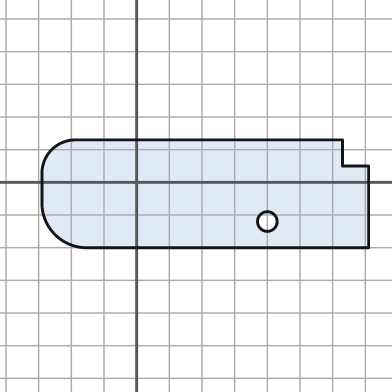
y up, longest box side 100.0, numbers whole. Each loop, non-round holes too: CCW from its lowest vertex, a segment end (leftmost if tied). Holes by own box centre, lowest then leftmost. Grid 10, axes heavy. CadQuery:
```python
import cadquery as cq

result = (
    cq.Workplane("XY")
    .moveTo(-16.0, -20.0)
    .lineTo(71.0, -20.0)
    .lineTo(71.0, 5.0)
    .lineTo(63.0, 5.0)
    .lineTo(63.0, 13.0)
    .lineTo(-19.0, 13.0)
    .threePointArc((-26.0, 10.0), (-29.0, 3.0))
    .lineTo(-29.0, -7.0)
    .threePointArc((-25.0, -16.0), (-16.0, -20.0))
    .close()
    .moveTo(40.0, -12.0)
    .circle(3.0)
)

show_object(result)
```